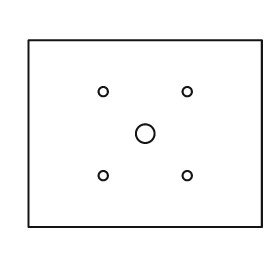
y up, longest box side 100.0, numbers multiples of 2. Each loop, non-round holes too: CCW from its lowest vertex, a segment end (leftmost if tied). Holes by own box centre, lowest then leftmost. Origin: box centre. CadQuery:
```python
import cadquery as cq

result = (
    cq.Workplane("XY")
    .moveTo(-50.0, -40.0)
    .lineTo(50.0, -40.0)
    .lineTo(50.0, 40.0)
    .lineTo(-50.0, 40.0)
    .close()
    .moveTo(-18.0, -18.0)
    .circle(2.0)
    .moveTo(18.0, -18.0)
    .circle(2.0)
    .moveTo(0.0, 0.0)
    .circle(4.0)
    .moveTo(-18.0, 18.0)
    .circle(2.0)
    .moveTo(18.0, 18.0)
    .circle(2.0)
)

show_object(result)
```